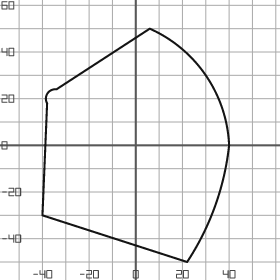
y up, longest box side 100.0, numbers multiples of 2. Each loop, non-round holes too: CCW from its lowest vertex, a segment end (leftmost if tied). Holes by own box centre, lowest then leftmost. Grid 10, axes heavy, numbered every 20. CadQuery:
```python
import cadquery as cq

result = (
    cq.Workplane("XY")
    .moveTo(22.0, -50.0)
    .threePointArc((34.0, -26.0), (40.0, 0.0))
    .threePointArc((30.0, 30.0), (6.0, 50.0))
    .lineTo(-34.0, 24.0)
    .threePointArc((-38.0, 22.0), (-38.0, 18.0))
    .lineTo(-40.0, -30.0)
    .close()
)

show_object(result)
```